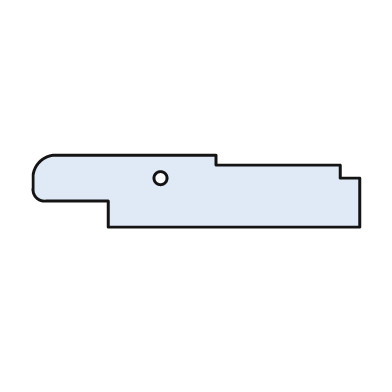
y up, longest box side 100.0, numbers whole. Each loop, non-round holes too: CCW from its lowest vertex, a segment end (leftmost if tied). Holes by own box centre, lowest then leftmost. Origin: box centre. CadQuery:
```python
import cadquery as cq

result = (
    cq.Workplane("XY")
    .moveTo(-27.0, -11.0)
    .lineTo(50.0, -11.0)
    .lineTo(50.0, 4.0)
    .lineTo(44.0, 4.0)
    .lineTo(44.0, 8.0)
    .lineTo(6.0, 8.0)
    .lineTo(6.0, 11.0)
    .lineTo(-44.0, 11.0)
    .threePointArc((-48.0, 9.0), (-50.0, 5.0))
    .lineTo(-50.0, 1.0)
    .threePointArc((-49.0, -2.0), (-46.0, -3.0))
    .lineTo(-27.0, -3.0)
    .close()
    .moveTo(-11.0, 4.0)
    .circle(2.0)
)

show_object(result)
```